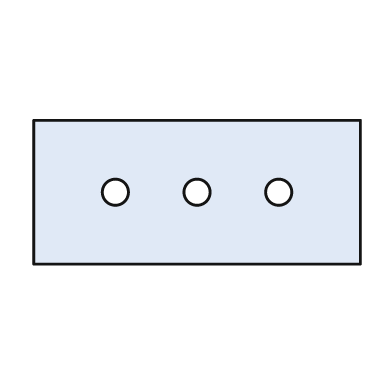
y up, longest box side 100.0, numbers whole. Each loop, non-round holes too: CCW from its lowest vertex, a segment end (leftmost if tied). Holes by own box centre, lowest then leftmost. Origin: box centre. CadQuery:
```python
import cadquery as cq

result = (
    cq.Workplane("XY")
    .moveTo(-50.0, -22.0)
    .lineTo(50.0, -22.0)
    .lineTo(50.0, 22.0)
    .lineTo(-50.0, 22.0)
    .close()
    .moveTo(-25.0, 0.0)
    .circle(4.0)
    .moveTo(0.0, 0.0)
    .circle(4.0)
    .moveTo(25.0, 0.0)
    .circle(4.0)
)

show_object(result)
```